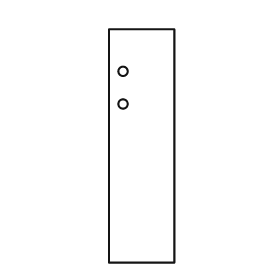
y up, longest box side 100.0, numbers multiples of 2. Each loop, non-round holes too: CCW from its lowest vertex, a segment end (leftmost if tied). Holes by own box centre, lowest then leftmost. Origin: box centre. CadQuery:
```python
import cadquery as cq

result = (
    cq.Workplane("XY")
    .moveTo(-14.0, -50.0)
    .lineTo(14.0, -50.0)
    .lineTo(14.0, 50.0)
    .lineTo(-14.0, 50.0)
    .close()
    .moveTo(-8.0, 18.0)
    .circle(2.0)
    .moveTo(-8.0, 32.0)
    .circle(2.0)
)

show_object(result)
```